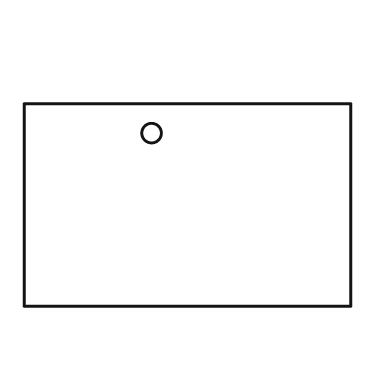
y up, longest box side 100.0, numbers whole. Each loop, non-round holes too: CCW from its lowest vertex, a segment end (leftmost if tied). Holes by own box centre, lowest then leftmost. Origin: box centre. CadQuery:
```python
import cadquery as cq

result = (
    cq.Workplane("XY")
    .moveTo(-50.0, -31.0)
    .lineTo(50.0, -31.0)
    .lineTo(50.0, 31.0)
    .lineTo(-50.0, 31.0)
    .close()
    .moveTo(-11.0, 22.0)
    .circle(3.0)
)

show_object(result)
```